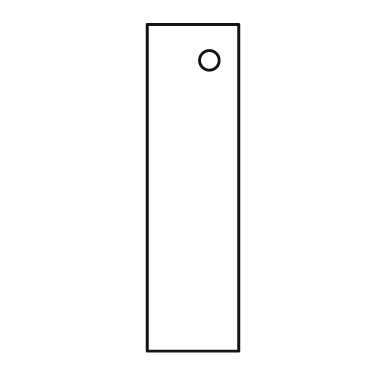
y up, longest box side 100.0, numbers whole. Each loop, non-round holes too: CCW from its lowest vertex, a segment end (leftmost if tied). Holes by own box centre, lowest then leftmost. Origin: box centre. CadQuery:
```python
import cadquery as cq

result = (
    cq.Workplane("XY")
    .moveTo(-14.0, -50.0)
    .lineTo(14.0, -50.0)
    .lineTo(14.0, 50.0)
    .lineTo(-14.0, 50.0)
    .close()
    .moveTo(5.0, 39.0)
    .circle(3.0)
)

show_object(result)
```